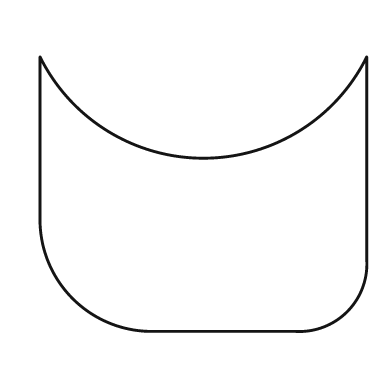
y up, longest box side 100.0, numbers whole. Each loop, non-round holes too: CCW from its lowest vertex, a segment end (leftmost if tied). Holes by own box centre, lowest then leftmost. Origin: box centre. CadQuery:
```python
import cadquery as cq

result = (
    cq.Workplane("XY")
    .moveTo(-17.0, -42.0)
    .lineTo(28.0, -42.0)
    .threePointArc((44.0, -36.0), (50.0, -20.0))
    .lineTo(50.0, 42.0)
    .threePointArc((0.0, 11.0), (-50.0, 42.0))
    .lineTo(-50.0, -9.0)
    .threePointArc((-40.0, -32.0), (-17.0, -42.0))
    .close()
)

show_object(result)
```